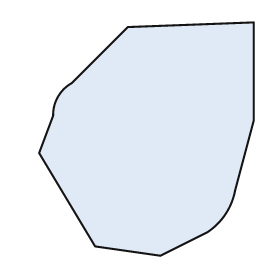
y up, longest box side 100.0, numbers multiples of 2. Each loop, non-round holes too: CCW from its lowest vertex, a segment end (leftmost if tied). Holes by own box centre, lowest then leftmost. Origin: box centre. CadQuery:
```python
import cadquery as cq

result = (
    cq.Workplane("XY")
    .moveTo(6.0, -50.0)
    .lineTo(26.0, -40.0)
    .threePointArc((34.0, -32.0), (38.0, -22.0))
    .lineTo(46.0, 8.0)
    .lineTo(46.0, 50.0)
    .lineTo(-8.0, 48.0)
    .lineTo(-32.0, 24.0)
    .threePointArc((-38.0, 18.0), (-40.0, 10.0))
    .lineTo(-46.0, -6.0)
    .lineTo(-22.0, -46.0)
    .close()
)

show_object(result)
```